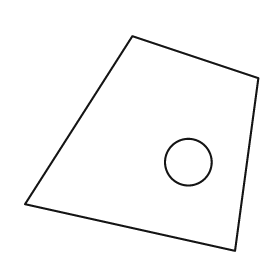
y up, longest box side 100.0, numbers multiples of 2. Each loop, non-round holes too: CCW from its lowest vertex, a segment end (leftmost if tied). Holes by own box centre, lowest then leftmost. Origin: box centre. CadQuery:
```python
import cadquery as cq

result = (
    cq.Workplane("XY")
    .moveTo(40.0, -46.0)
    .lineTo(50.0, 28.0)
    .lineTo(-4.0, 46.0)
    .lineTo(-50.0, -26.0)
    .close()
    .moveTo(20.0, -8.0)
    .circle(10.0)
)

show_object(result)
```